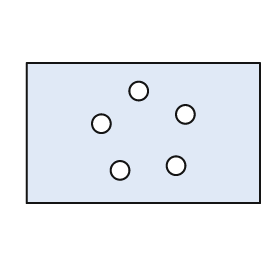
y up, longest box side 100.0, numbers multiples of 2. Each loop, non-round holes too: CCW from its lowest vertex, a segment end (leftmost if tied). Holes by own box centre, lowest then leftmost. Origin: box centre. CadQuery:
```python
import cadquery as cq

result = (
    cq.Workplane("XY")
    .moveTo(-50.0, -30.0)
    .lineTo(50.0, -30.0)
    .lineTo(50.0, 30.0)
    .lineTo(-50.0, 30.0)
    .close()
    .moveTo(-10.0, -16.0)
    .circle(4.0)
    .moveTo(14.0, -14.0)
    .circle(4.0)
    .moveTo(-18.0, 4.0)
    .circle(4.0)
    .moveTo(18.0, 8.0)
    .circle(4.0)
    .moveTo(-2.0, 18.0)
    .circle(4.0)
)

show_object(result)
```